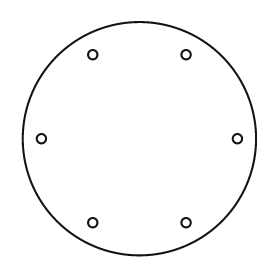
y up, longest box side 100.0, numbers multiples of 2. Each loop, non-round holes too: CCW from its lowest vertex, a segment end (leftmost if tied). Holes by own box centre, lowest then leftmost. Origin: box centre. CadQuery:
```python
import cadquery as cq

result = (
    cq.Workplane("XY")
    .moveTo(0.0, 0.0)
    .circle(50.0)
    .moveTo(-20.0, -36.0)
    .circle(2.0)
    .moveTo(20.0, -36.0)
    .circle(2.0)
    .moveTo(-42.0, 0.0)
    .circle(2.0)
    .moveTo(42.0, 0.0)
    .circle(2.0)
    .moveTo(-20.0, 36.0)
    .circle(2.0)
    .moveTo(20.0, 36.0)
    .circle(2.0)
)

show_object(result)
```